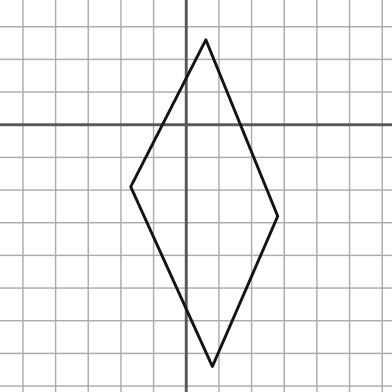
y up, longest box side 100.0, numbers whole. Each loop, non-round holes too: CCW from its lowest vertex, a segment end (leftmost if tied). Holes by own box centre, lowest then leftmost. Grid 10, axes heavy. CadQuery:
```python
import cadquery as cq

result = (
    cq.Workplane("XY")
    .moveTo(8.0, -74.0)
    .lineTo(28.0, -28.0)
    .lineTo(6.0, 26.0)
    .lineTo(-17.0, -19.0)
    .close()
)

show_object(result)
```